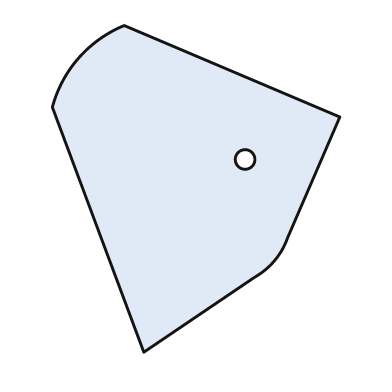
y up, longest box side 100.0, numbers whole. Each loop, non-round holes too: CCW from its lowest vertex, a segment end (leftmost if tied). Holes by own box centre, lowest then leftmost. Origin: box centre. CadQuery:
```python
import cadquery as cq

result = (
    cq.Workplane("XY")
    .moveTo(-16.0, -50.0)
    .lineTo(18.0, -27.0)
    .threePointArc((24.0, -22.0), (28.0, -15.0))
    .lineTo(44.0, 22.0)
    .lineTo(-22.0, 50.0)
    .threePointArc((-36.0, 40.0), (-44.0, 25.0))
    .close()
    .moveTo(15.0, 9.0)
    .circle(3.0)
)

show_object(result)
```